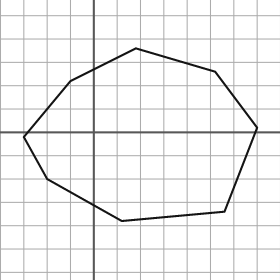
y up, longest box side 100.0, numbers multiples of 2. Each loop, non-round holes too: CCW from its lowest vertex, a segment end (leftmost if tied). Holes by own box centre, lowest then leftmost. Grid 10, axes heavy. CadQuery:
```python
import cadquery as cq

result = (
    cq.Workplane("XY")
    .moveTo(12.0, -38.0)
    .lineTo(56.0, -34.0)
    .lineTo(70.0, 2.0)
    .lineTo(52.0, 26.0)
    .lineTo(18.0, 36.0)
    .lineTo(-10.0, 22.0)
    .lineTo(-30.0, -2.0)
    .lineTo(-20.0, -20.0)
    .close()
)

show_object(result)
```